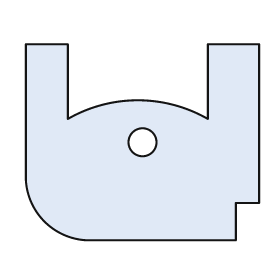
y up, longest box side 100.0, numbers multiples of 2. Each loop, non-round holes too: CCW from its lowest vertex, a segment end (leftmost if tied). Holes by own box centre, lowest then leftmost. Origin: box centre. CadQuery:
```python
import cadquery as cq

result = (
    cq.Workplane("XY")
    .moveTo(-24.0, -42.0)
    .lineTo(40.0, -42.0)
    .lineTo(40.0, -26.0)
    .lineTo(50.0, -26.0)
    .lineTo(50.0, 42.0)
    .lineTo(28.0, 42.0)
    .lineTo(28.0, 10.0)
    .threePointArc((-2.0, 18.0), (-32.0, 10.0))
    .lineTo(-32.0, 42.0)
    .lineTo(-50.0, 42.0)
    .lineTo(-50.0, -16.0)
    .threePointArc((-42.0, -34.0), (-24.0, -42.0))
    .close()
    .moveTo(0.0, 0.0)
    .circle(6.0)
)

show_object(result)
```